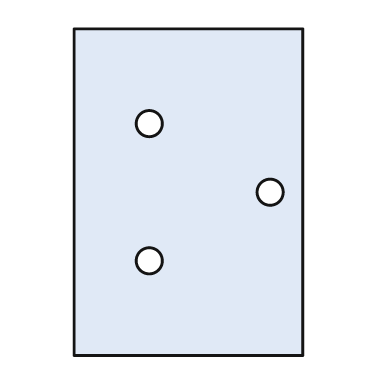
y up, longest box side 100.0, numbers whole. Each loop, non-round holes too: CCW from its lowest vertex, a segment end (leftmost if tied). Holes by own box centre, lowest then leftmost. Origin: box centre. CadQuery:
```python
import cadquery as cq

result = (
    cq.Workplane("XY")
    .moveTo(-35.0, -50.0)
    .lineTo(35.0, -50.0)
    .lineTo(35.0, 50.0)
    .lineTo(-35.0, 50.0)
    .close()
    .moveTo(-12.0, -21.0)
    .circle(4.0)
    .moveTo(25.0, 0.0)
    .circle(4.0)
    .moveTo(-12.0, 21.0)
    .circle(4.0)
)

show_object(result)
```